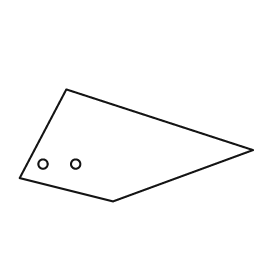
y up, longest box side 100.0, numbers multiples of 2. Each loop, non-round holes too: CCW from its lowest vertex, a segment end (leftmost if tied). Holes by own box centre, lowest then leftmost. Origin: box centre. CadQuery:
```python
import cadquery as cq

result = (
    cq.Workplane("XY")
    .moveTo(-10.0, -24.0)
    .lineTo(50.0, -2.0)
    .lineTo(-30.0, 24.0)
    .lineTo(-50.0, -14.0)
    .close()
    .moveTo(-40.0, -8.0)
    .circle(2.0)
    .moveTo(-26.0, -8.0)
    .circle(2.0)
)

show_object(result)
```